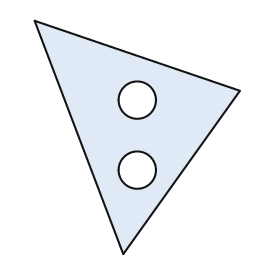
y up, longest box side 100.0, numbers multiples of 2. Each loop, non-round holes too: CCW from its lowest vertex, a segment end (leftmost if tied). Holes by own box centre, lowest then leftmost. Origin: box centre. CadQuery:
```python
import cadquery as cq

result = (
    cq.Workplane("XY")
    .moveTo(-6.0, -50.0)
    .lineTo(44.0, 20.0)
    .lineTo(-44.0, 50.0)
    .close()
    .moveTo(0.0, -14.0)
    .circle(8.0)
    .moveTo(0.0, 16.0)
    .circle(8.0)
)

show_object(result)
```